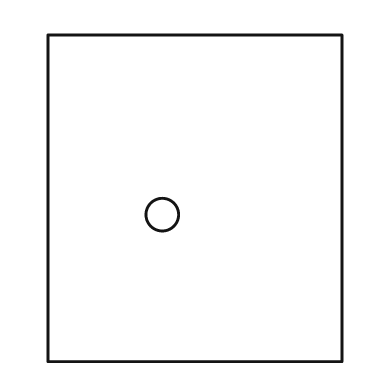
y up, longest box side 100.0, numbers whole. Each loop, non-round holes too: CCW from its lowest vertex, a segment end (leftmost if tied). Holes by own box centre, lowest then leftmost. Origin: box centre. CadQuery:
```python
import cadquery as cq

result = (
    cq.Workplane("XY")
    .moveTo(-45.0, -50.0)
    .lineTo(45.0, -50.0)
    .lineTo(45.0, 50.0)
    .lineTo(-45.0, 50.0)
    .close()
    .moveTo(-10.0, -5.0)
    .circle(5.0)
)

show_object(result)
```